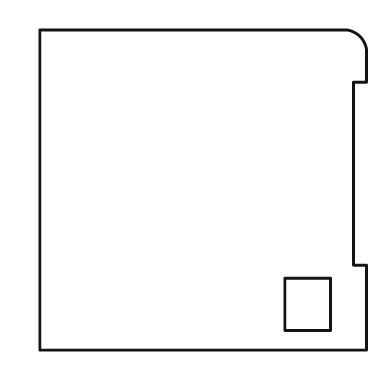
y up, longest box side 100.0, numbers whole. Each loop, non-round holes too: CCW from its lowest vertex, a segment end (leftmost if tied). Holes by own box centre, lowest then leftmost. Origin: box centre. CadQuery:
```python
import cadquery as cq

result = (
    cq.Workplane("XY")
    .moveTo(-50.0, -49.0)
    .lineTo(50.0, -49.0)
    .lineTo(50.0, -23.0)
    .lineTo(46.0, -23.0)
    .lineTo(46.0, 33.0)
    .lineTo(50.0, 33.0)
    .lineTo(50.0, 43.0)
    .threePointArc((48.0, 47.0), (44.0, 49.0))
    .lineTo(-50.0, 49.0)
    .close()
    .moveTo(25.0, -43.0)
    .lineTo(39.0, -43.0)
    .lineTo(39.0, -27.0)
    .lineTo(25.0, -27.0)
    .close()
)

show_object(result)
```